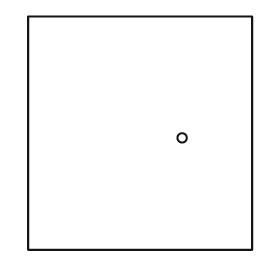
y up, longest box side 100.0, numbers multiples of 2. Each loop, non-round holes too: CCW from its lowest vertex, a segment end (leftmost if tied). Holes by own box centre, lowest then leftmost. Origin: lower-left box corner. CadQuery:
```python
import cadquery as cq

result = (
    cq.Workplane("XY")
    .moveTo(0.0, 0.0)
    .lineTo(96.0, 0.0)
    .lineTo(96.0, 100.0)
    .lineTo(0.0, 100.0)
    .close()
    .moveTo(66.0, 48.0)
    .circle(2.0)
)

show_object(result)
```